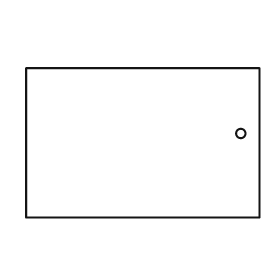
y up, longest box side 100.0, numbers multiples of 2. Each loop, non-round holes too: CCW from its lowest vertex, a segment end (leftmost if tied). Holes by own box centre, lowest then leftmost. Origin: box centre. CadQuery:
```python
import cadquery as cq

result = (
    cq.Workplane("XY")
    .moveTo(-50.0, -32.0)
    .lineTo(50.0, -32.0)
    .lineTo(50.0, 32.0)
    .lineTo(-50.0, 32.0)
    .close()
    .moveTo(42.0, 4.0)
    .circle(2.0)
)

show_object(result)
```